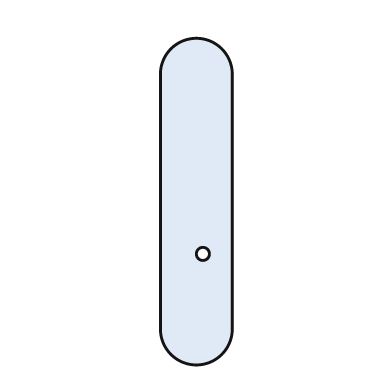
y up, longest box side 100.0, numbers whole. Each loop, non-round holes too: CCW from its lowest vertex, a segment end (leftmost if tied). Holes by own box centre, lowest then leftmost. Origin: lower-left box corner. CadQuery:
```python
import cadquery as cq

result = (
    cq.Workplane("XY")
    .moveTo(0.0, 11.0)
    .threePointArc((11.0, 0.0), (22.0, 11.0))
    .lineTo(22.0, 89.0)
    .threePointArc((11.0, 100.0), (0.0, 89.0))
    .close()
    .moveTo(13.0, 34.0)
    .circle(2.0)
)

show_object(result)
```